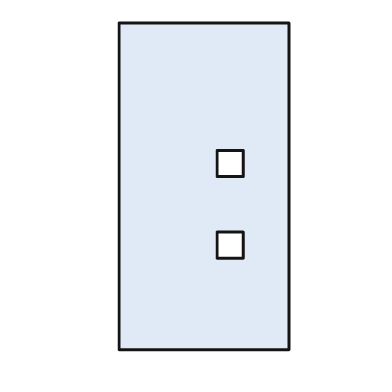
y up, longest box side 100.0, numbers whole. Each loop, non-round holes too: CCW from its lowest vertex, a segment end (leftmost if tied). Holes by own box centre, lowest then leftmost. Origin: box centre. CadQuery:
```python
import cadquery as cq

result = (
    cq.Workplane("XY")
    .moveTo(-26.0, -50.0)
    .lineTo(26.0, -50.0)
    .lineTo(26.0, 50.0)
    .lineTo(-26.0, 50.0)
    .close()
    .moveTo(4.0, -22.0)
    .lineTo(12.0, -22.0)
    .lineTo(12.0, -14.0)
    .lineTo(4.0, -14.0)
    .close()
    .moveTo(4.0, 3.0)
    .lineTo(12.0, 3.0)
    .lineTo(12.0, 11.0)
    .lineTo(4.0, 11.0)
    .close()
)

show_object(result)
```